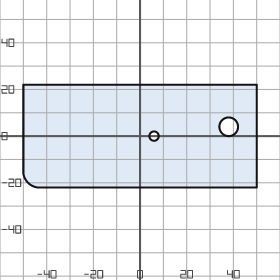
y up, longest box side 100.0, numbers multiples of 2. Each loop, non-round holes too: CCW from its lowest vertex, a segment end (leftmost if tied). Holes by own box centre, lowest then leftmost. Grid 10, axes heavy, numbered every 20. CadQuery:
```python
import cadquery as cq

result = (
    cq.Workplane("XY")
    .moveTo(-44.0, -22.0)
    .lineTo(50.0, -22.0)
    .lineTo(50.0, 22.0)
    .lineTo(-50.0, 22.0)
    .lineTo(-50.0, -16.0)
    .threePointArc((-48.0, -20.0), (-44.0, -22.0))
    .close()
    .moveTo(6.0, 0.0)
    .circle(2.0)
    .moveTo(38.0, 4.0)
    .circle(4.0)
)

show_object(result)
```